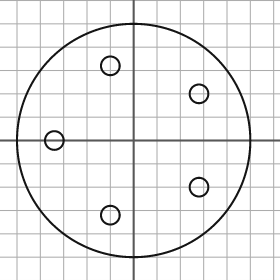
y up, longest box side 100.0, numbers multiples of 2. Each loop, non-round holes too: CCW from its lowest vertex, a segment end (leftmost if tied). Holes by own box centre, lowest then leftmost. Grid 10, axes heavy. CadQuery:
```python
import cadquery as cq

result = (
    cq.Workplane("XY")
    .moveTo(0.0, 0.0)
    .circle(50.0)
    .moveTo(-10.0, -32.0)
    .circle(4.0)
    .moveTo(28.0, -20.0)
    .circle(4.0)
    .moveTo(-34.0, 0.0)
    .circle(4.0)
    .moveTo(28.0, 20.0)
    .circle(4.0)
    .moveTo(-10.0, 32.0)
    .circle(4.0)
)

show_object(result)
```